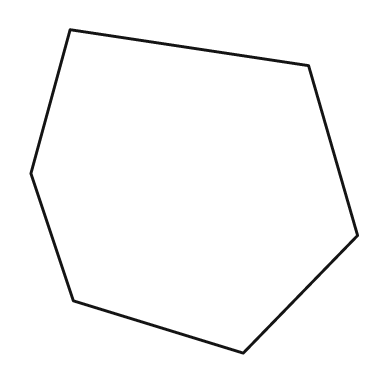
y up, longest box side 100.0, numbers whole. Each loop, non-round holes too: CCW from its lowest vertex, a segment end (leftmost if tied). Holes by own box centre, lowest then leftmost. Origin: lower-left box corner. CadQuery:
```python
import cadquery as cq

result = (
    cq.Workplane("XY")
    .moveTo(65.0, 0.0)
    .lineTo(100.0, 36.0)
    .lineTo(85.0, 88.0)
    .lineTo(12.0, 99.0)
    .lineTo(0.0, 55.0)
    .lineTo(13.0, 16.0)
    .close()
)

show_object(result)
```